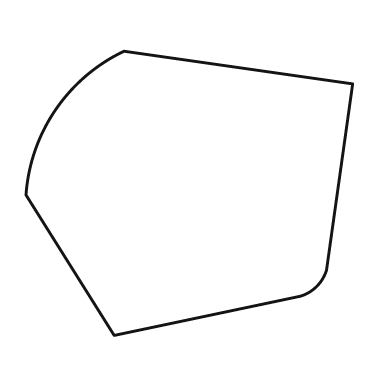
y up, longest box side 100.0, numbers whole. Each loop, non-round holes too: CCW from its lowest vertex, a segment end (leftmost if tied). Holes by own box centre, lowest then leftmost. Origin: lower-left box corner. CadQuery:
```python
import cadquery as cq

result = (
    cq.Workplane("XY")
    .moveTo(27.0, 0.0)
    .lineTo(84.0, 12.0)
    .threePointArc((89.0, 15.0), (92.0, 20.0))
    .lineTo(100.0, 77.0)
    .lineTo(30.0, 87.0)
    .threePointArc((9.0, 69.0), (0.0, 43.0))
    .close()
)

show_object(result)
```